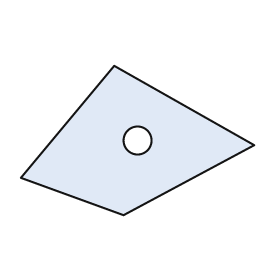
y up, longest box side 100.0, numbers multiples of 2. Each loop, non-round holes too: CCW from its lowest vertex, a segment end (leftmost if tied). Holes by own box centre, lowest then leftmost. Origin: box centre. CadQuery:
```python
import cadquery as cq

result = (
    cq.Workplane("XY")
    .moveTo(-6.0, -32.0)
    .lineTo(50.0, -2.0)
    .lineTo(-10.0, 32.0)
    .lineTo(-50.0, -16.0)
    .close()
    .moveTo(0.0, 0.0)
    .circle(6.0)
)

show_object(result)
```